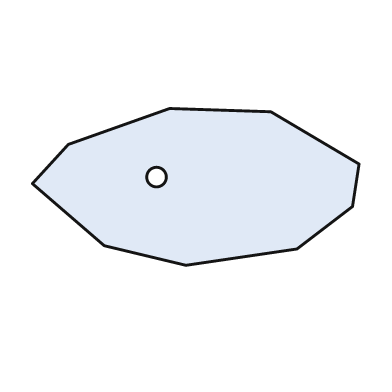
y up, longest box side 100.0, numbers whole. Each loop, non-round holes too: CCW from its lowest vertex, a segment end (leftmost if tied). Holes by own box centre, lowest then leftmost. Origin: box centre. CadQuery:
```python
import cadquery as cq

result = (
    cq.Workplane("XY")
    .moveTo(-3.0, -24.0)
    .lineTo(31.0, -19.0)
    .lineTo(48.0, -6.0)
    .lineTo(50.0, 7.0)
    .lineTo(23.0, 23.0)
    .lineTo(-8.0, 24.0)
    .lineTo(-39.0, 13.0)
    .lineTo(-50.0, 1.0)
    .lineTo(-28.0, -18.0)
    .close()
    .moveTo(-12.0, 3.0)
    .circle(3.0)
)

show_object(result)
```